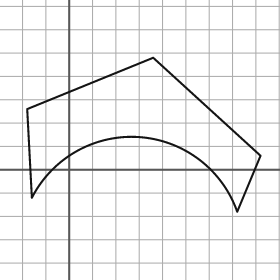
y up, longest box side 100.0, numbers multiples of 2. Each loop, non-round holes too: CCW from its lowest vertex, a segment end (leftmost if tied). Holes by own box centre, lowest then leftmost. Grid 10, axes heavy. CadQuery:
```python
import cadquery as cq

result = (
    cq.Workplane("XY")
    .moveTo(72.0, -18.0)
    .lineTo(82.0, 6.0)
    .lineTo(36.0, 48.0)
    .lineTo(-18.0, 26.0)
    .lineTo(-16.0, -12.0)
    .threePointArc((30.0, 14.0), (72.0, -18.0))
    .close()
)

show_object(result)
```